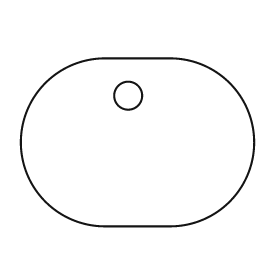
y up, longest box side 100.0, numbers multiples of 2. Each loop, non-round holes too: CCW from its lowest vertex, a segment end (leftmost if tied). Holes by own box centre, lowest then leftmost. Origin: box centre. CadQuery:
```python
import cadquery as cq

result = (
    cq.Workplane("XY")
    .moveTo(-14.0, -36.0)
    .lineTo(14.0, -36.0)
    .threePointArc((50.0, 0.0), (14.0, 36.0))
    .lineTo(-14.0, 36.0)
    .threePointArc((-50.0, 0.0), (-14.0, -36.0))
    .close()
    .moveTo(-4.0, 20.0)
    .circle(6.0)
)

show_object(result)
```